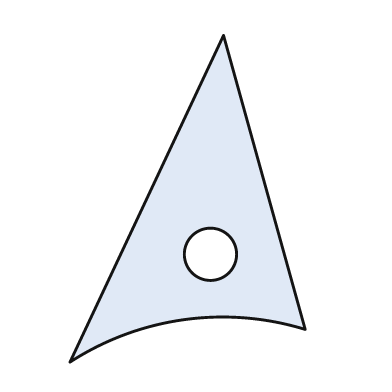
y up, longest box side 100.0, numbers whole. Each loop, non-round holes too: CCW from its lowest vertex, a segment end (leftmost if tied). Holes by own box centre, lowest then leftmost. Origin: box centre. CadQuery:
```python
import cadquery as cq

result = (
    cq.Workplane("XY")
    .moveTo(-36.0, -50.0)
    .threePointArc((-1.0, -37.0), (36.0, -40.0))
    .lineTo(11.0, 50.0)
    .close()
    .moveTo(7.0, -17.0)
    .circle(8.0)
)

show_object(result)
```